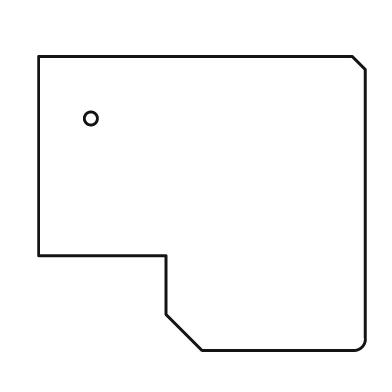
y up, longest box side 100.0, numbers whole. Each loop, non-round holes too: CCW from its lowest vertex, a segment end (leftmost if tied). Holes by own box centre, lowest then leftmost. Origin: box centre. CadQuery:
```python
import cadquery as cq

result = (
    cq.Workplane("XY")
    .moveTo(0.0, -45.0)
    .lineTo(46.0, -45.0)
    .threePointArc((49.0, -44.0), (50.0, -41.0))
    .lineTo(50.0, 41.0)
    .lineTo(46.0, 45.0)
    .lineTo(-50.0, 45.0)
    .lineTo(-50.0, -16.0)
    .lineTo(-11.0, -16.0)
    .lineTo(-11.0, -34.0)
    .close()
    .moveTo(-34.0, 26.0)
    .circle(2.0)
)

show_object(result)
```